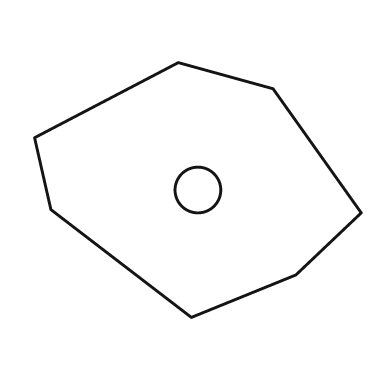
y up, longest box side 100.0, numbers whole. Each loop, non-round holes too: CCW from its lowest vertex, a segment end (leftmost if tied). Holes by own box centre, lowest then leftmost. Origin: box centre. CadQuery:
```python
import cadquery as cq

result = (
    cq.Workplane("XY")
    .moveTo(-2.0, -39.0)
    .lineTo(30.0, -26.0)
    .lineTo(50.0, -7.0)
    .lineTo(23.0, 31.0)
    .lineTo(-6.0, 39.0)
    .lineTo(-50.0, 16.0)
    .lineTo(-45.0, -6.0)
    .close()
    .moveTo(0.0, 0.0)
    .circle(7.0)
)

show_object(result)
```